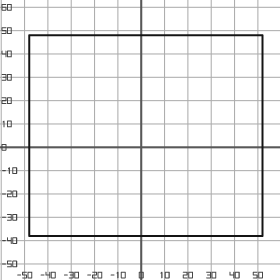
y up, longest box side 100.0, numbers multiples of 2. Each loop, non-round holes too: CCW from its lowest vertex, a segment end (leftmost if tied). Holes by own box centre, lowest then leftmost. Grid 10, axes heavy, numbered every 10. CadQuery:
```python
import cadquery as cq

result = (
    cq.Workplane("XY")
    .moveTo(-48.0, -38.0)
    .lineTo(52.0, -38.0)
    .lineTo(52.0, 48.0)
    .lineTo(-48.0, 48.0)
    .close()
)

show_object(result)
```